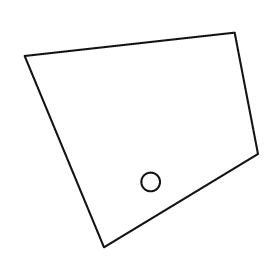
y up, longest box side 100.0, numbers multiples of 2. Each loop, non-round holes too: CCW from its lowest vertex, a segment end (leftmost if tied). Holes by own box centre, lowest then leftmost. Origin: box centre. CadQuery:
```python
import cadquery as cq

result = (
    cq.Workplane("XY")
    .moveTo(-16.0, -46.0)
    .lineTo(50.0, -6.0)
    .lineTo(40.0, 46.0)
    .lineTo(-50.0, 36.0)
    .close()
    .moveTo(4.0, -18.0)
    .circle(4.0)
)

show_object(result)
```